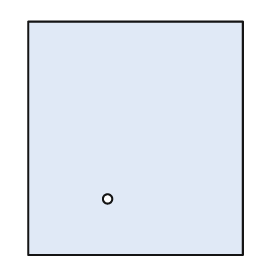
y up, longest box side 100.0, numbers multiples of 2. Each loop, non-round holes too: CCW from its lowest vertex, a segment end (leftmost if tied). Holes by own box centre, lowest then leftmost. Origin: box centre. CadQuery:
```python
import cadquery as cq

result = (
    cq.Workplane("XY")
    .moveTo(-46.0, -50.0)
    .lineTo(46.0, -50.0)
    .lineTo(46.0, 50.0)
    .lineTo(-46.0, 50.0)
    .close()
    .moveTo(-12.0, -26.0)
    .circle(2.0)
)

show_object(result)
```